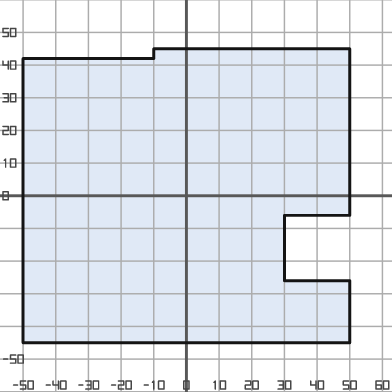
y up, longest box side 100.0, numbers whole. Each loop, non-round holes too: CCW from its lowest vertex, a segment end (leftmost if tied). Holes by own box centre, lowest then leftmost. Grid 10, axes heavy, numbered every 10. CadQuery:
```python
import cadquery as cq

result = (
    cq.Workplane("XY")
    .moveTo(-50.0, -45.0)
    .lineTo(50.0, -45.0)
    .lineTo(50.0, -26.0)
    .lineTo(30.0, -26.0)
    .lineTo(30.0, -6.0)
    .lineTo(50.0, -6.0)
    .lineTo(50.0, 45.0)
    .lineTo(-10.0, 45.0)
    .lineTo(-10.0, 42.0)
    .lineTo(-50.0, 42.0)
    .close()
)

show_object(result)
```